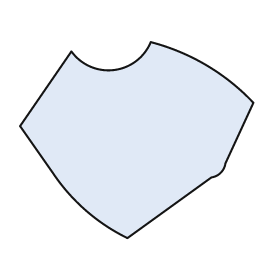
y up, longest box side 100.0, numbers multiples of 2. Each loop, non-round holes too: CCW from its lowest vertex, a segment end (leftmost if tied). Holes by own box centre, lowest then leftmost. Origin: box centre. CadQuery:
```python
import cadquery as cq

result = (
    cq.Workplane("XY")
    .moveTo(-4.0, -42.0)
    .lineTo(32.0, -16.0)
    .threePointArc((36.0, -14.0), (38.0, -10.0))
    .lineTo(50.0, 16.0)
    .threePointArc((30.0, 32.0), (6.0, 42.0))
    .threePointArc((-10.0, 30.0), (-28.0, 38.0))
    .lineTo(-50.0, 6.0)
    .lineTo(-36.0, -14.0)
    .threePointArc((-22.0, -30.0), (-4.0, -42.0))
    .close()
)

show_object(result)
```